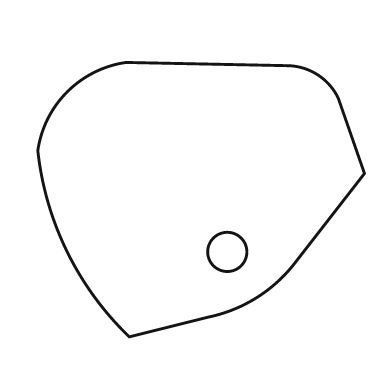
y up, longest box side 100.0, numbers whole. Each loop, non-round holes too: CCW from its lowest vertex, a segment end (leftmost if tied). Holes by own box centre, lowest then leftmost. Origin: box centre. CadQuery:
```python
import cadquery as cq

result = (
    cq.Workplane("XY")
    .moveTo(-22.0, -42.0)
    .lineTo(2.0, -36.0)
    .threePointArc((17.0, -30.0), (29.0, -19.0))
    .lineTo(50.0, 8.0)
    .lineTo(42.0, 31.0)
    .threePointArc((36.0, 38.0), (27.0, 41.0))
    .lineTo(-23.0, 42.0)
    .threePointArc((-41.0, 33.0), (-50.0, 15.0))
    .threePointArc((-41.0, -16.0), (-22.0, -42.0))
    .close()
    .moveTo(8.0, -16.0)
    .circle(6.0)
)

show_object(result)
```